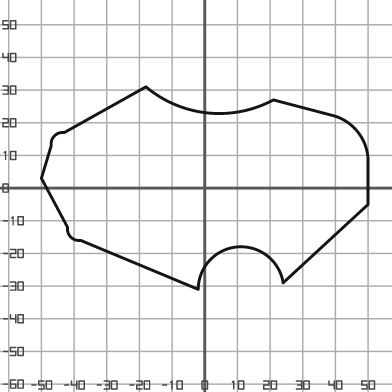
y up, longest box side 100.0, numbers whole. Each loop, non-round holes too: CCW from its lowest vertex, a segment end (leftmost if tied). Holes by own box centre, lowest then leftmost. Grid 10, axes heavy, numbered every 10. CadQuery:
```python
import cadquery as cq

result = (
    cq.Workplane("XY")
    .moveTo(-2.0, -31.0)
    .threePointArc((10.0, -18.0), (24.0, -29.0))
    .lineTo(50.0, -5.0)
    .lineTo(50.0, 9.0)
    .threePointArc((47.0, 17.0), (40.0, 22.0))
    .lineTo(21.0, 27.0)
    .threePointArc((1.0, 23.0), (-18.0, 31.0))
    .lineTo(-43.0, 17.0)
    .threePointArc((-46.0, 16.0), (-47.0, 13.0))
    .lineTo(-50.0, 3.0)
    .lineTo(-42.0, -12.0)
    .threePointArc((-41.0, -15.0), (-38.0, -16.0))
    .close()
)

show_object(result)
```